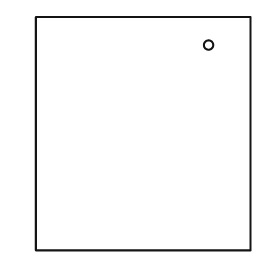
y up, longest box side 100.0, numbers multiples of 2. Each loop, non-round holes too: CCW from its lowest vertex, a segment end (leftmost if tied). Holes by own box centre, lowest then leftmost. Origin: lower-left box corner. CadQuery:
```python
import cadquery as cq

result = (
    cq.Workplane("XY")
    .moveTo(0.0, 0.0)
    .lineTo(92.0, 0.0)
    .lineTo(92.0, 100.0)
    .lineTo(0.0, 100.0)
    .close()
    .moveTo(74.0, 88.0)
    .circle(2.0)
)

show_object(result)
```